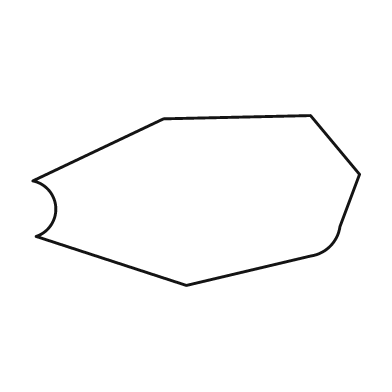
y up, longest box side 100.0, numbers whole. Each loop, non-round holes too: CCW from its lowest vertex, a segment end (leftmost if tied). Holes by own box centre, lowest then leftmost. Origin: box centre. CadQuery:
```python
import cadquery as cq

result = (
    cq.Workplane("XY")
    .moveTo(-3.0, -26.0)
    .lineTo(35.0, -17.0)
    .threePointArc((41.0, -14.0), (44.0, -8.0))
    .lineTo(50.0, 8.0)
    .lineTo(35.0, 26.0)
    .lineTo(-10.0, 25.0)
    .lineTo(-50.0, 6.0)
    .threePointArc((-43.0, -2.0), (-49.0, -11.0))
    .close()
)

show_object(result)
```